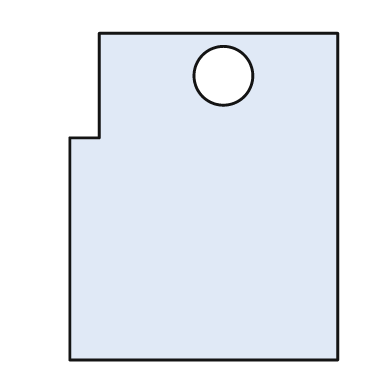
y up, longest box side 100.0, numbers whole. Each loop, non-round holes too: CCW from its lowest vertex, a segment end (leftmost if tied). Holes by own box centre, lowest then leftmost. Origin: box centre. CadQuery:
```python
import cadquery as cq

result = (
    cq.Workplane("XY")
    .moveTo(-41.0, -50.0)
    .lineTo(41.0, -50.0)
    .lineTo(41.0, 50.0)
    .lineTo(-32.0, 50.0)
    .lineTo(-32.0, 18.0)
    .lineTo(-41.0, 18.0)
    .close()
    .moveTo(6.0, 37.0)
    .circle(9.0)
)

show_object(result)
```